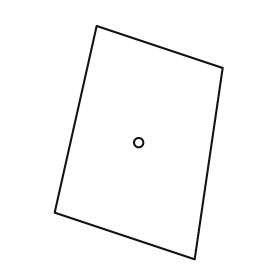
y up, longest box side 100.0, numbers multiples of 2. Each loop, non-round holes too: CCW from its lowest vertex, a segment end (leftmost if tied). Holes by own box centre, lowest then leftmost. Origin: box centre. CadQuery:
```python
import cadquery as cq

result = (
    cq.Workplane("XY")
    .moveTo(24.0, -50.0)
    .lineTo(36.0, 32.0)
    .lineTo(-18.0, 50.0)
    .lineTo(-36.0, -30.0)
    .close()
    .moveTo(0.0, 0.0)
    .circle(2.0)
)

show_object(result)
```